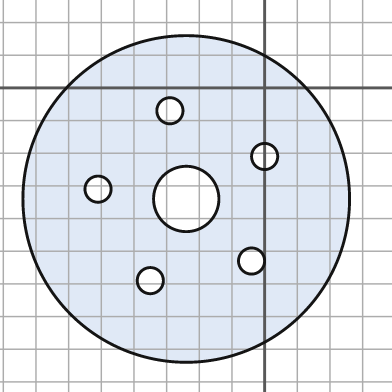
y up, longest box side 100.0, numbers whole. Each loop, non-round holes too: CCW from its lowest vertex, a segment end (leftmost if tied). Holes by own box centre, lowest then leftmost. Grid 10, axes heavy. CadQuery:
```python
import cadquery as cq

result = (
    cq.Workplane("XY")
    .moveTo(-24.0, -34.0)
    .circle(50.0)
    .moveTo(-35.0, -59.0)
    .circle(4.0)
    .moveTo(-4.0, -53.0)
    .circle(4.0)
    .moveTo(-24.0, -34.0)
    .circle(10.0)
    .moveTo(-51.0, -31.0)
    .circle(4.0)
    .moveTo(0.0, -21.0)
    .circle(4.0)
    .moveTo(-29.0, -7.0)
    .circle(4.0)
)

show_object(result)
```